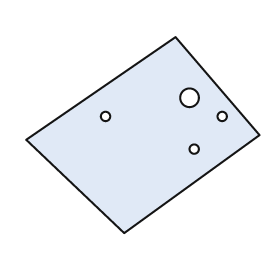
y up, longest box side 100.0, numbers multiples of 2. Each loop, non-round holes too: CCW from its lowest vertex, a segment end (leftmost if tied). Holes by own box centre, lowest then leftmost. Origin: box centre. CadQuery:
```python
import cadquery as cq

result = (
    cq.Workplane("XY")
    .moveTo(-8.0, -42.0)
    .lineTo(50.0, 0.0)
    .lineTo(14.0, 42.0)
    .lineTo(-50.0, -2.0)
    .close()
    .moveTo(22.0, -6.0)
    .circle(2.0)
    .moveTo(-16.0, 8.0)
    .circle(2.0)
    .moveTo(34.0, 8.0)
    .circle(2.0)
    .moveTo(20.0, 16.0)
    .circle(4.0)
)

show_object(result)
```